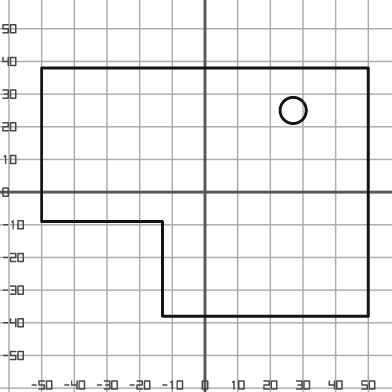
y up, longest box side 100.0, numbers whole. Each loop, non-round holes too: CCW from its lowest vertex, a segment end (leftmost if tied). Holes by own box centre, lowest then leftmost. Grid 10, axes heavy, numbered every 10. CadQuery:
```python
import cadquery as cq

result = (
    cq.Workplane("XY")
    .moveTo(-13.0, -38.0)
    .lineTo(50.0, -38.0)
    .lineTo(50.0, 38.0)
    .lineTo(-50.0, 38.0)
    .lineTo(-50.0, -9.0)
    .lineTo(-13.0, -9.0)
    .close()
    .moveTo(27.0, 25.0)
    .circle(4.0)
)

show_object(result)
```